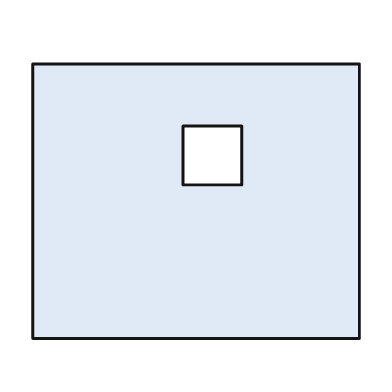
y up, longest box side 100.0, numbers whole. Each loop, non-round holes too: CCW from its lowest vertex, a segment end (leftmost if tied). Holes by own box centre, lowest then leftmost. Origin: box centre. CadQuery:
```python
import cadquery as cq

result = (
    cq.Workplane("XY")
    .moveTo(-50.0, -42.0)
    .lineTo(50.0, -42.0)
    .lineTo(50.0, 42.0)
    .lineTo(-50.0, 42.0)
    .close()
    .moveTo(-4.0, 5.0)
    .lineTo(14.0, 5.0)
    .lineTo(14.0, 23.0)
    .lineTo(-4.0, 23.0)
    .close()
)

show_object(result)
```